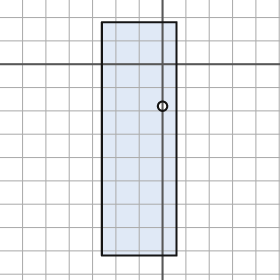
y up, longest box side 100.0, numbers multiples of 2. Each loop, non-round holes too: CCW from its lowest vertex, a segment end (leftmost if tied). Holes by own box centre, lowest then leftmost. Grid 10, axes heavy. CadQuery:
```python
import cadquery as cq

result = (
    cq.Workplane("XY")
    .moveTo(-26.0, -82.0)
    .lineTo(6.0, -82.0)
    .lineTo(6.0, 18.0)
    .lineTo(-26.0, 18.0)
    .close()
    .moveTo(0.0, -18.0)
    .circle(2.0)
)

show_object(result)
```